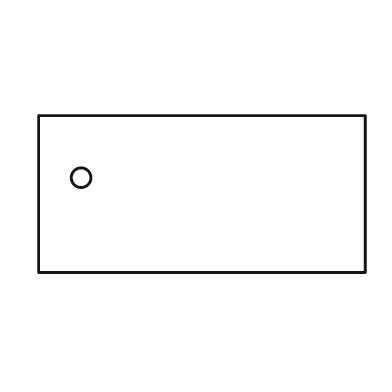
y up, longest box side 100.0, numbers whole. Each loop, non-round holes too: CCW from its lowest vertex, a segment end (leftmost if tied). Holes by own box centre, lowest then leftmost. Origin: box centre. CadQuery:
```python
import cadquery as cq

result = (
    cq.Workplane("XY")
    .moveTo(-50.0, -24.0)
    .lineTo(50.0, -24.0)
    .lineTo(50.0, 24.0)
    .lineTo(-50.0, 24.0)
    .close()
    .moveTo(-37.0, 5.0)
    .circle(3.0)
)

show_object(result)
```